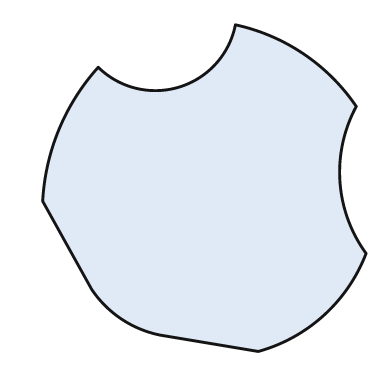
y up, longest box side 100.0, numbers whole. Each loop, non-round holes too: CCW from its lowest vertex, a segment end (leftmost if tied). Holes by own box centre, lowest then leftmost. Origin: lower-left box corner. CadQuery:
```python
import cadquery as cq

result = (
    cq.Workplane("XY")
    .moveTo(66.0, 0.0)
    .threePointArc((86.0, 11.0), (99.0, 30.0))
    .threePointArc((91.0, 52.0), (96.0, 75.0))
    .threePointArc((80.0, 91.0), (59.0, 100.0))
    .threePointArc((42.0, 81.0), (17.0, 87.0))
    .threePointArc((5.0, 68.0), (0.0, 46.0))
    .lineTo(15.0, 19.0)
    .threePointArc((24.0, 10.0), (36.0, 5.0))
    .close()
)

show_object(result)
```